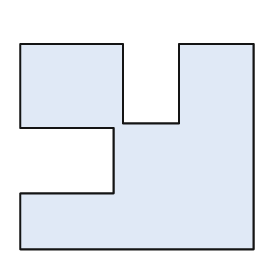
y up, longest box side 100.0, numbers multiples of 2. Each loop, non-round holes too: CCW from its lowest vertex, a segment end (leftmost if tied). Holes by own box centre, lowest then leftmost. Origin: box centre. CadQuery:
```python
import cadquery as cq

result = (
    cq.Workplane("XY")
    .moveTo(-50.0, -44.0)
    .lineTo(50.0, -44.0)
    .lineTo(50.0, 44.0)
    .lineTo(18.0, 44.0)
    .lineTo(18.0, 10.0)
    .lineTo(-6.0, 10.0)
    .lineTo(-6.0, 44.0)
    .lineTo(-50.0, 44.0)
    .lineTo(-50.0, 8.0)
    .lineTo(-10.0, 8.0)
    .lineTo(-10.0, -20.0)
    .lineTo(-50.0, -20.0)
    .close()
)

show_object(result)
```